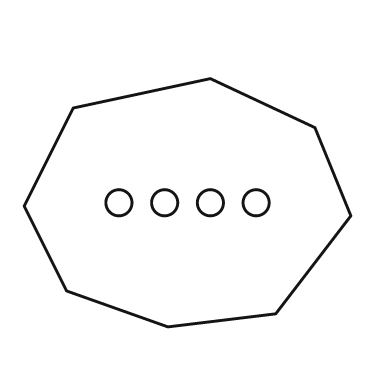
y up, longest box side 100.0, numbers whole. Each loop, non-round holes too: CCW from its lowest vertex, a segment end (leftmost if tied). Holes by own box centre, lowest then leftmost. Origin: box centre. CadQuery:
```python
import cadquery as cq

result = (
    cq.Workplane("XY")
    .moveTo(-6.0, -38.0)
    .lineTo(27.0, -34.0)
    .lineTo(50.0, -4.0)
    .lineTo(39.0, 23.0)
    .lineTo(7.0, 38.0)
    .lineTo(-35.0, 29.0)
    .lineTo(-50.0, -1.0)
    .lineTo(-37.0, -27.0)
    .close()
    .moveTo(-21.0, 0.0)
    .circle(4.0)
    .moveTo(-7.0, 0.0)
    .circle(4.0)
    .moveTo(7.0, 0.0)
    .circle(4.0)
    .moveTo(21.0, 0.0)
    .circle(4.0)
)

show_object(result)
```